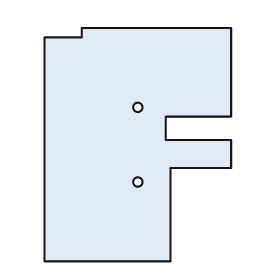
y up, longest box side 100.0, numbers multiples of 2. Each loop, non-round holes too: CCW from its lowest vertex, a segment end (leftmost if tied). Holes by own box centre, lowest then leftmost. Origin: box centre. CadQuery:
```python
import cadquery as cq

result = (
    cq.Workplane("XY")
    .moveTo(-40.0, -50.0)
    .lineTo(14.0, -50.0)
    .lineTo(14.0, -10.0)
    .lineTo(40.0, -10.0)
    .lineTo(40.0, 2.0)
    .lineTo(12.0, 2.0)
    .lineTo(12.0, 12.0)
    .lineTo(40.0, 12.0)
    .lineTo(40.0, 50.0)
    .lineTo(-24.0, 50.0)
    .lineTo(-24.0, 46.0)
    .lineTo(-40.0, 46.0)
    .close()
    .moveTo(0.0, -16.0)
    .circle(2.0)
    .moveTo(0.0, 16.0)
    .circle(2.0)
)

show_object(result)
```